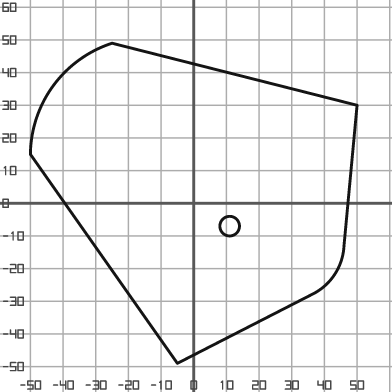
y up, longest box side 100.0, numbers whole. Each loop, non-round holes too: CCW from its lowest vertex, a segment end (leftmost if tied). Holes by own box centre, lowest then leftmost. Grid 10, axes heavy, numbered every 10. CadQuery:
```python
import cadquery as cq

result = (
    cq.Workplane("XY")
    .moveTo(-5.0, -49.0)
    .lineTo(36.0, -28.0)
    .threePointArc((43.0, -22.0), (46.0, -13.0))
    .lineTo(50.0, 30.0)
    .lineTo(-25.0, 49.0)
    .threePointArc((-43.0, 36.0), (-50.0, 15.0))
    .close()
    .moveTo(11.0, -7.0)
    .circle(3.0)
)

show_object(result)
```